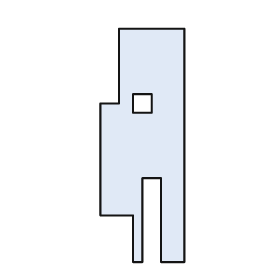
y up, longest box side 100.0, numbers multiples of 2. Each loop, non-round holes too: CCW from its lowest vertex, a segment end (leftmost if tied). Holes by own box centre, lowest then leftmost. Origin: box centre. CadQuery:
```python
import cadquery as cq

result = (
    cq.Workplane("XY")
    .moveTo(-4.0, -50.0)
    .lineTo(0.0, -50.0)
    .lineTo(0.0, -14.0)
    .lineTo(8.0, -14.0)
    .lineTo(8.0, -50.0)
    .lineTo(18.0, -50.0)
    .lineTo(18.0, 50.0)
    .lineTo(-10.0, 50.0)
    .lineTo(-10.0, 18.0)
    .lineTo(-18.0, 18.0)
    .lineTo(-18.0, -30.0)
    .lineTo(-4.0, -30.0)
    .close()
    .moveTo(-4.0, 14.0)
    .lineTo(4.0, 14.0)
    .lineTo(4.0, 22.0)
    .lineTo(-4.0, 22.0)
    .close()
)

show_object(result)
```